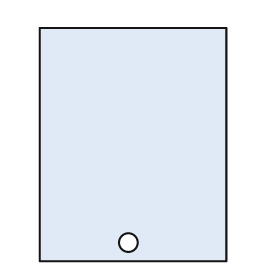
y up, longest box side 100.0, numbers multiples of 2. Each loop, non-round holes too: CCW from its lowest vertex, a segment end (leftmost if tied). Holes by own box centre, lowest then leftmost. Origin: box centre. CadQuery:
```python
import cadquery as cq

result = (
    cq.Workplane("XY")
    .moveTo(-40.0, -50.0)
    .lineTo(40.0, -50.0)
    .lineTo(40.0, 50.0)
    .lineTo(-40.0, 50.0)
    .close()
    .moveTo(-2.0, -42.0)
    .circle(4.0)
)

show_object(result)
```